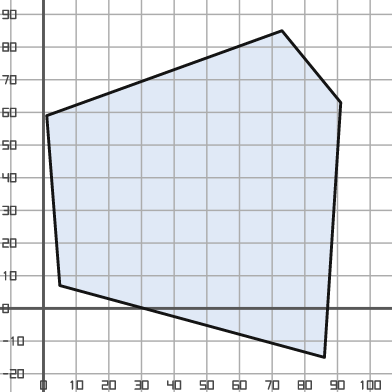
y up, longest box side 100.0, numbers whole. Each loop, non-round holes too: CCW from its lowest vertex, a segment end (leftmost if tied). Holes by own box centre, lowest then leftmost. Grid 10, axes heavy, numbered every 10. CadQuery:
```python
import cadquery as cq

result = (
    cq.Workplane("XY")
    .moveTo(86.0, -15.0)
    .lineTo(91.0, 63.0)
    .lineTo(73.0, 85.0)
    .lineTo(1.0, 59.0)
    .lineTo(5.0, 7.0)
    .close()
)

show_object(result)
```